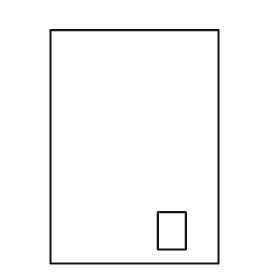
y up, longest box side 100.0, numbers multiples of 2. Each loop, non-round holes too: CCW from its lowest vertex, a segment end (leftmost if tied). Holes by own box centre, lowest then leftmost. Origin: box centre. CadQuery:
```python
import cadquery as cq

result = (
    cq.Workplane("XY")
    .moveTo(-36.0, -50.0)
    .lineTo(36.0, -50.0)
    .lineTo(36.0, 50.0)
    .lineTo(-36.0, 50.0)
    .close()
    .moveTo(10.0, -44.0)
    .lineTo(22.0, -44.0)
    .lineTo(22.0, -28.0)
    .lineTo(10.0, -28.0)
    .close()
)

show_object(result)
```